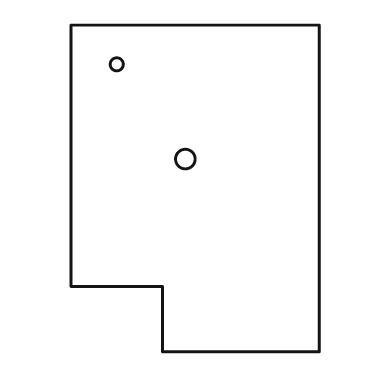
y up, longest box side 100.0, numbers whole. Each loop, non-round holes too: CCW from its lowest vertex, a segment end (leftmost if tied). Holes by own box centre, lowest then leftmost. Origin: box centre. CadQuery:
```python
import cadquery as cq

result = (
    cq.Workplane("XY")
    .moveTo(-10.0, -50.0)
    .lineTo(38.0, -50.0)
    .lineTo(38.0, 50.0)
    .lineTo(-38.0, 50.0)
    .lineTo(-38.0, -30.0)
    .lineTo(-10.0, -30.0)
    .close()
    .moveTo(-3.0, 9.0)
    .circle(3.0)
    .moveTo(-24.0, 38.0)
    .circle(2.0)
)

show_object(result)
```